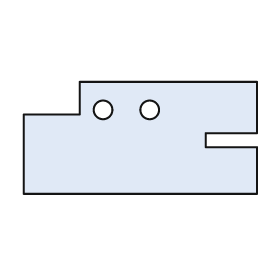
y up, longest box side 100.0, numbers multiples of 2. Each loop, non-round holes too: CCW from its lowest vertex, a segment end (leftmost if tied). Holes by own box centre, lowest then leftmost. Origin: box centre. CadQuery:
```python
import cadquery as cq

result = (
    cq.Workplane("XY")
    .moveTo(-50.0, -24.0)
    .lineTo(50.0, -24.0)
    .lineTo(50.0, -4.0)
    .lineTo(28.0, -4.0)
    .lineTo(28.0, 2.0)
    .lineTo(50.0, 2.0)
    .lineTo(50.0, 24.0)
    .lineTo(-26.0, 24.0)
    .lineTo(-26.0, 10.0)
    .lineTo(-50.0, 10.0)
    .close()
    .moveTo(-16.0, 12.0)
    .circle(4.0)
    .moveTo(4.0, 12.0)
    .circle(4.0)
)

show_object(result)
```